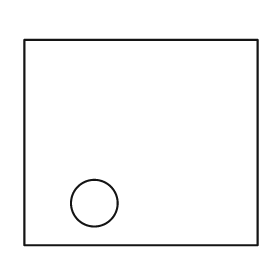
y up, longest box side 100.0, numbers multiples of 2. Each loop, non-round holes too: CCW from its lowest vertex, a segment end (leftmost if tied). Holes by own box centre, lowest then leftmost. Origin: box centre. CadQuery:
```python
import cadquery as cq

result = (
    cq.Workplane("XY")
    .moveTo(-50.0, -44.0)
    .lineTo(50.0, -44.0)
    .lineTo(50.0, 44.0)
    .lineTo(-50.0, 44.0)
    .close()
    .moveTo(-20.0, -26.0)
    .circle(10.0)
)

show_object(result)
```